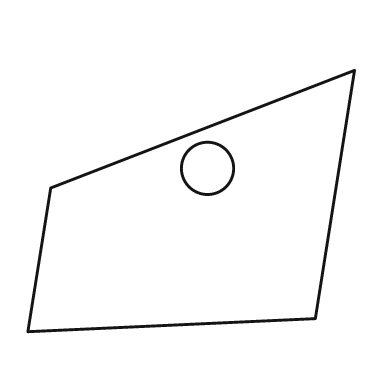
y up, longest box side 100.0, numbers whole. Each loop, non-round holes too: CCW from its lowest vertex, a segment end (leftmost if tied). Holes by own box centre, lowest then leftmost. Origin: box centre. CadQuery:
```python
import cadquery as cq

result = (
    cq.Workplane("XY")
    .moveTo(-50.0, -40.0)
    .lineTo(38.0, -36.0)
    .lineTo(50.0, 40.0)
    .lineTo(-43.0, 4.0)
    .close()
    .moveTo(5.0, 10.0)
    .circle(8.0)
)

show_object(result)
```